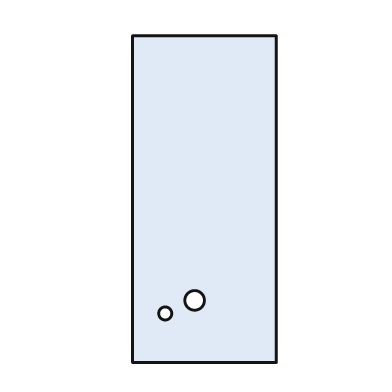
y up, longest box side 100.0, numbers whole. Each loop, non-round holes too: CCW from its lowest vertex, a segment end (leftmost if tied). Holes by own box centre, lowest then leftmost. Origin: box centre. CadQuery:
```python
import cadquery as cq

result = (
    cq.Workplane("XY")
    .moveTo(-22.0, -50.0)
    .lineTo(22.0, -50.0)
    .lineTo(22.0, 50.0)
    .lineTo(-22.0, 50.0)
    .close()
    .moveTo(-12.0, -35.0)
    .circle(2.0)
    .moveTo(-3.0, -31.0)
    .circle(3.0)
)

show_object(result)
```